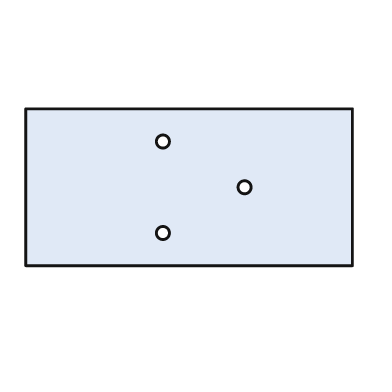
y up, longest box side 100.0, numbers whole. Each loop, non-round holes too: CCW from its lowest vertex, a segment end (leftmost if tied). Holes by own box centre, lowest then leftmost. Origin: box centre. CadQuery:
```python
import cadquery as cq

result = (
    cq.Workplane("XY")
    .moveTo(-50.0, -24.0)
    .lineTo(50.0, -24.0)
    .lineTo(50.0, 24.0)
    .lineTo(-50.0, 24.0)
    .close()
    .moveTo(-8.0, -14.0)
    .circle(2.0)
    .moveTo(17.0, 0.0)
    .circle(2.0)
    .moveTo(-8.0, 14.0)
    .circle(2.0)
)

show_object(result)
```